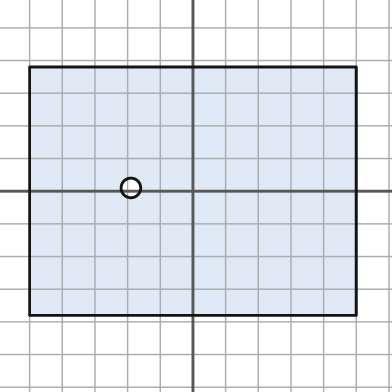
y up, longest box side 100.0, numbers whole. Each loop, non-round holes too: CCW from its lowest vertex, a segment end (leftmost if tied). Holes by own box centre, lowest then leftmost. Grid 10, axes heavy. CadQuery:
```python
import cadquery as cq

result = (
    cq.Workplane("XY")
    .moveTo(-50.0, -38.0)
    .lineTo(50.0, -38.0)
    .lineTo(50.0, 38.0)
    .lineTo(-50.0, 38.0)
    .close()
    .moveTo(-19.0, 1.0)
    .circle(3.0)
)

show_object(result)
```